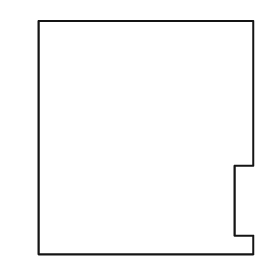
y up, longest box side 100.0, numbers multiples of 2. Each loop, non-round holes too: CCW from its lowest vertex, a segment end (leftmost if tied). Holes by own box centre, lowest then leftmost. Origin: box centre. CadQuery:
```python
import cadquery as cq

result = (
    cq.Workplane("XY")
    .moveTo(-46.0, -50.0)
    .lineTo(46.0, -50.0)
    .lineTo(46.0, -42.0)
    .lineTo(38.0, -42.0)
    .lineTo(38.0, -12.0)
    .lineTo(46.0, -12.0)
    .lineTo(46.0, 50.0)
    .lineTo(-46.0, 50.0)
    .close()
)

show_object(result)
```